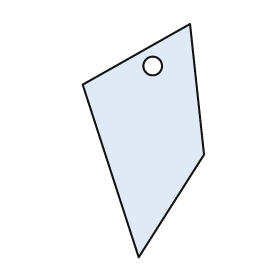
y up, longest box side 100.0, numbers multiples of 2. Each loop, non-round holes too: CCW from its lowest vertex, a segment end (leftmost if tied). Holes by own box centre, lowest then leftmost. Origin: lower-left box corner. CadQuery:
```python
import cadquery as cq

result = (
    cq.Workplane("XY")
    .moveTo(24.0, 0.0)
    .lineTo(52.0, 44.0)
    .lineTo(46.0, 100.0)
    .lineTo(0.0, 74.0)
    .close()
    .moveTo(30.0, 82.0)
    .circle(4.0)
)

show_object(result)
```